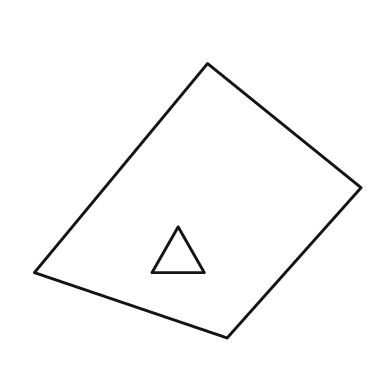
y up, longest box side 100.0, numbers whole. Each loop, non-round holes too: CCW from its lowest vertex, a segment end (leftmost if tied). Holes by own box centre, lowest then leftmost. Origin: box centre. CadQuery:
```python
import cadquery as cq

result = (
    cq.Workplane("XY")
    .moveTo(9.0, -42.0)
    .lineTo(50.0, 4.0)
    .lineTo(3.0, 42.0)
    .lineTo(-50.0, -22.0)
    .close()
    .moveTo(-14.0, -22.0)
    .lineTo(2.0, -22.0)
    .lineTo(-6.0, -8.0)
    .close()
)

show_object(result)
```